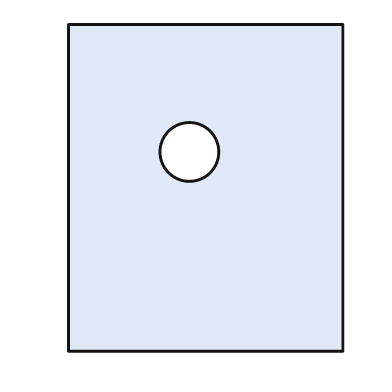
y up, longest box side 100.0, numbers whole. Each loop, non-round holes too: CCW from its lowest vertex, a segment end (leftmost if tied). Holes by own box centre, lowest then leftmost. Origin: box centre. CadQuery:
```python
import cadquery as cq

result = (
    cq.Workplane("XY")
    .moveTo(-42.0, -50.0)
    .lineTo(42.0, -50.0)
    .lineTo(42.0, 50.0)
    .lineTo(-42.0, 50.0)
    .close()
    .moveTo(-5.0, 11.0)
    .circle(9.0)
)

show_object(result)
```